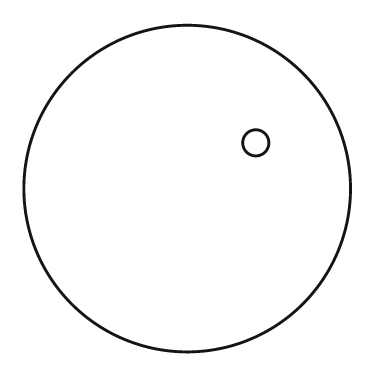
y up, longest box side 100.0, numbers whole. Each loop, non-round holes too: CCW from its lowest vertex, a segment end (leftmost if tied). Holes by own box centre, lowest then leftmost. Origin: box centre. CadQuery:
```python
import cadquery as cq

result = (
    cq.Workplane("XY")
    .moveTo(0.0, 0.0)
    .circle(50.0)
    .moveTo(21.0, 14.0)
    .circle(4.0)
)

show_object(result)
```